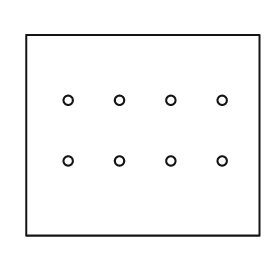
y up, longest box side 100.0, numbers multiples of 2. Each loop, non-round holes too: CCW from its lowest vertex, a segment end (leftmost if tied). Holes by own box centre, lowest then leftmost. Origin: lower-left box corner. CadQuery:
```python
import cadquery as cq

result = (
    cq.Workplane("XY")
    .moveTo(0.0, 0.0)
    .lineTo(100.0, 0.0)
    .lineTo(100.0, 86.0)
    .lineTo(0.0, 86.0)
    .close()
    .moveTo(18.0, 32.0)
    .circle(2.0)
    .moveTo(40.0, 32.0)
    .circle(2.0)
    .moveTo(62.0, 32.0)
    .circle(2.0)
    .moveTo(84.0, 32.0)
    .circle(2.0)
    .moveTo(18.0, 58.0)
    .circle(2.0)
    .moveTo(40.0, 58.0)
    .circle(2.0)
    .moveTo(62.0, 58.0)
    .circle(2.0)
    .moveTo(84.0, 58.0)
    .circle(2.0)
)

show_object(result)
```